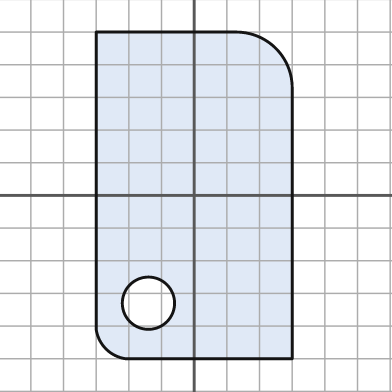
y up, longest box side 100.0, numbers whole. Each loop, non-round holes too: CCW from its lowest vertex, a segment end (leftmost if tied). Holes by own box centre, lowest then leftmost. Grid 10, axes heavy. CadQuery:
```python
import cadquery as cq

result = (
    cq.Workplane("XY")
    .moveTo(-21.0, -50.0)
    .lineTo(30.0, -50.0)
    .lineTo(30.0, 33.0)
    .threePointArc((25.0, 45.0), (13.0, 50.0))
    .lineTo(-30.0, 50.0)
    .lineTo(-30.0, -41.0)
    .threePointArc((-27.0, -47.0), (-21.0, -50.0))
    .close()
    .moveTo(-14.0, -33.0)
    .circle(8.0)
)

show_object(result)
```